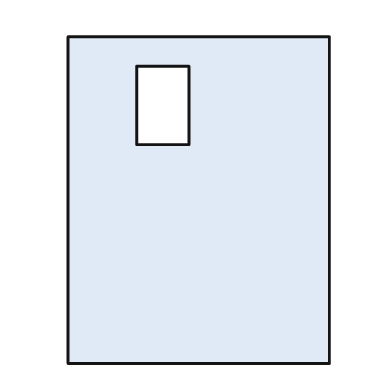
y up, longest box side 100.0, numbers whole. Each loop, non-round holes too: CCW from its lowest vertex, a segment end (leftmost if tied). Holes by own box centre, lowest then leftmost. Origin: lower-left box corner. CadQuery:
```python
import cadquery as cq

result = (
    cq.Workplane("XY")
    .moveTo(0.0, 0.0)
    .lineTo(80.0, 0.0)
    .lineTo(80.0, 100.0)
    .lineTo(0.0, 100.0)
    .close()
    .moveTo(21.0, 67.0)
    .lineTo(37.0, 67.0)
    .lineTo(37.0, 91.0)
    .lineTo(21.0, 91.0)
    .close()
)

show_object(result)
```